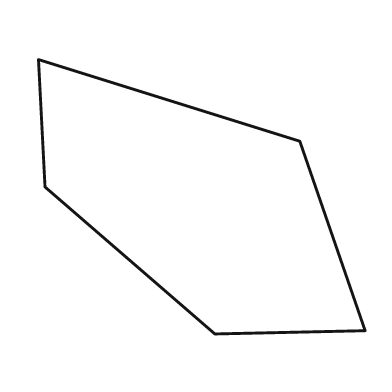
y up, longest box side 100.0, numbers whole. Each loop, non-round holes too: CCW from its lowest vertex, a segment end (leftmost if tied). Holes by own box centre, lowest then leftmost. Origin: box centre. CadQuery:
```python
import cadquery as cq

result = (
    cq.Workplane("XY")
    .moveTo(4.0, -42.0)
    .lineTo(50.0, -41.0)
    .lineTo(30.0, 17.0)
    .lineTo(-50.0, 42.0)
    .lineTo(-48.0, 3.0)
    .close()
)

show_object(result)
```